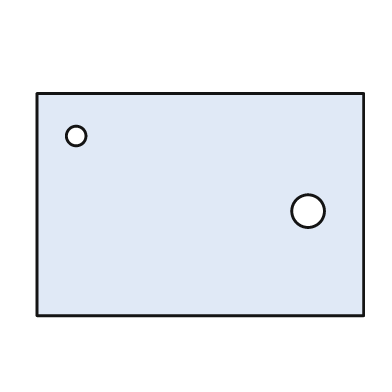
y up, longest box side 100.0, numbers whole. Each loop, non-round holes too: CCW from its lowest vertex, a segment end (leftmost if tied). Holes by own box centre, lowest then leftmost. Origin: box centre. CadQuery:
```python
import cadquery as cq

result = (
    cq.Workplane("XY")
    .moveTo(-50.0, -34.0)
    .lineTo(50.0, -34.0)
    .lineTo(50.0, 34.0)
    .lineTo(-50.0, 34.0)
    .close()
    .moveTo(33.0, -2.0)
    .circle(5.0)
    .moveTo(-38.0, 21.0)
    .circle(3.0)
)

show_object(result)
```